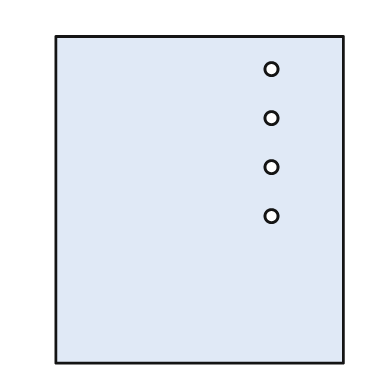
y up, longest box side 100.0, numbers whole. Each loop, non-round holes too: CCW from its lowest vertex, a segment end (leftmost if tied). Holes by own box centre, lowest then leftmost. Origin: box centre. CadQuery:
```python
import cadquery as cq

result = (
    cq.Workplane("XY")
    .moveTo(-44.0, -50.0)
    .lineTo(44.0, -50.0)
    .lineTo(44.0, 50.0)
    .lineTo(-44.0, 50.0)
    .close()
    .moveTo(22.0, -5.0)
    .circle(2.0)
    .moveTo(22.0, 10.0)
    .circle(2.0)
    .moveTo(22.0, 25.0)
    .circle(2.0)
    .moveTo(22.0, 40.0)
    .circle(2.0)
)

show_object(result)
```